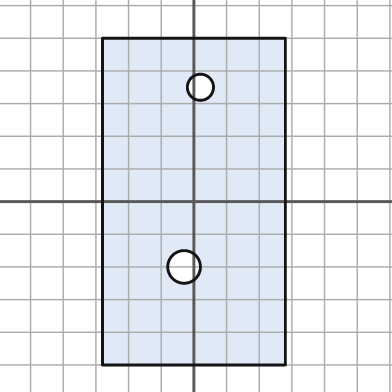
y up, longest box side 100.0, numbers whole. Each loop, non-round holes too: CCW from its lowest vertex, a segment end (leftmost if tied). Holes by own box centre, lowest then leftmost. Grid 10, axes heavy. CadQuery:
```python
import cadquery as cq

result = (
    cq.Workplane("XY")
    .moveTo(-28.0, -50.0)
    .lineTo(28.0, -50.0)
    .lineTo(28.0, 50.0)
    .lineTo(-28.0, 50.0)
    .close()
    .moveTo(-3.0, -20.0)
    .circle(5.0)
    .moveTo(2.0, 35.0)
    .circle(4.0)
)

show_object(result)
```